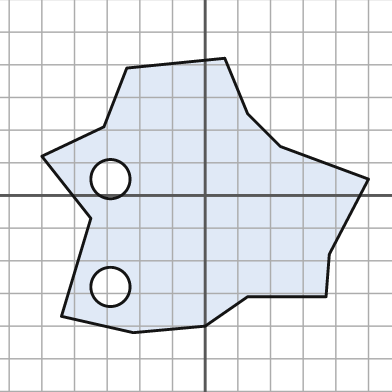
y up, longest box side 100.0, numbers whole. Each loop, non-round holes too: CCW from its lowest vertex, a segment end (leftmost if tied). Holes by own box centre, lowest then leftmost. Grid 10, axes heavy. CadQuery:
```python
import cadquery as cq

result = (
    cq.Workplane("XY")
    .moveTo(-22.0, -42.0)
    .lineTo(0.0, -40.0)
    .lineTo(13.0, -31.0)
    .lineTo(37.0, -31.0)
    .lineTo(38.0, -18.0)
    .lineTo(50.0, 5.0)
    .lineTo(23.0, 15.0)
    .lineTo(13.0, 25.0)
    .lineTo(6.0, 42.0)
    .lineTo(-24.0, 39.0)
    .lineTo(-31.0, 21.0)
    .lineTo(-50.0, 12.0)
    .lineTo(-35.0, -7.0)
    .lineTo(-44.0, -37.0)
    .close()
    .moveTo(-29.0, -28.0)
    .circle(6.0)
    .moveTo(-29.0, 5.0)
    .circle(6.0)
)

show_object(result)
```